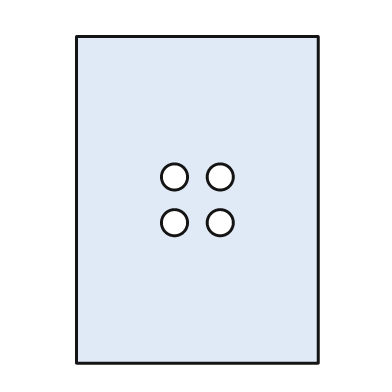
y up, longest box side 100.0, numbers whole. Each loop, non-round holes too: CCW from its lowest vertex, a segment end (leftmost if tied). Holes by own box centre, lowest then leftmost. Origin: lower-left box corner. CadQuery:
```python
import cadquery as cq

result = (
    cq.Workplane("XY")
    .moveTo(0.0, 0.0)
    .lineTo(74.0, 0.0)
    .lineTo(74.0, 100.0)
    .lineTo(0.0, 100.0)
    .close()
    .moveTo(30.0, 43.0)
    .circle(4.0)
    .moveTo(44.0, 43.0)
    .circle(4.0)
    .moveTo(30.0, 57.0)
    .circle(4.0)
    .moveTo(44.0, 57.0)
    .circle(4.0)
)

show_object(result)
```